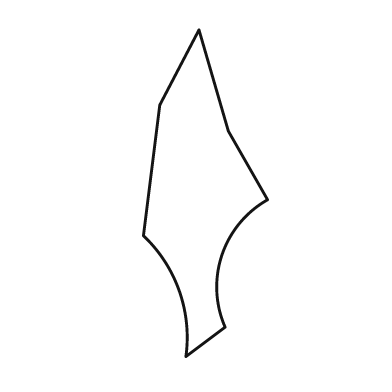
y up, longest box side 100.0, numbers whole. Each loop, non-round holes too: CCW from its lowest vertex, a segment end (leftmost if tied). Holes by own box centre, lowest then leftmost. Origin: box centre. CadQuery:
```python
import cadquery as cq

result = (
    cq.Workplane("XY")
    .moveTo(-6.0, -50.0)
    .lineTo(6.0, -41.0)
    .threePointArc((5.0, -19.0), (19.0, -2.0))
    .lineTo(7.0, 19.0)
    .lineTo(-2.0, 50.0)
    .lineTo(-14.0, 27.0)
    .lineTo(-19.0, -13.0)
    .threePointArc((-8.0, -30.0), (-6.0, -50.0))
    .close()
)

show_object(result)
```